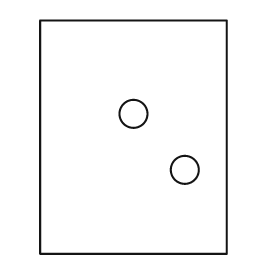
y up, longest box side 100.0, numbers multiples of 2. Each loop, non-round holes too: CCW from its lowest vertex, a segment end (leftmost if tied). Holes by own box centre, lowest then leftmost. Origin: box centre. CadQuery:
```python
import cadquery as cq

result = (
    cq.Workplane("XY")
    .moveTo(-40.0, -50.0)
    .lineTo(40.0, -50.0)
    .lineTo(40.0, 50.0)
    .lineTo(-40.0, 50.0)
    .close()
    .moveTo(22.0, -14.0)
    .circle(6.0)
    .moveTo(0.0, 10.0)
    .circle(6.0)
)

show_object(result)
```